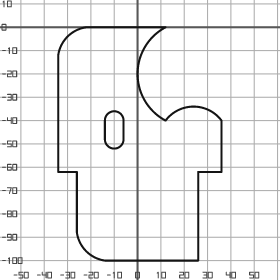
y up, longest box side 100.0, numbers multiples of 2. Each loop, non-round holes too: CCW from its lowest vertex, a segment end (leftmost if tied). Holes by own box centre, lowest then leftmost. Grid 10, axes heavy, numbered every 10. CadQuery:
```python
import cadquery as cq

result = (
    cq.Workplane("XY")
    .moveTo(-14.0, -100.0)
    .lineTo(26.0, -100.0)
    .lineTo(26.0, -62.0)
    .lineTo(36.0, -62.0)
    .lineTo(36.0, -40.0)
    .threePointArc((24.0, -34.0), (12.0, -40.0))
    .threePointArc((0.0, -20.0), (12.0, 0.0))
    .lineTo(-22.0, 0.0)
    .threePointArc((-30.0, -4.0), (-34.0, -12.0))
    .lineTo(-34.0, -62.0)
    .lineTo(-26.0, -62.0)
    .lineTo(-26.0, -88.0)
    .threePointArc((-22.0, -96.0), (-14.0, -100.0))
    .close()
    .moveTo(-14.0, -48.0)
    .threePointArc((-10.0, -52.0), (-6.0, -48.0))
    .lineTo(-6.0, -40.0)
    .threePointArc((-10.0, -36.0), (-14.0, -40.0))
    .close()
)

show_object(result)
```